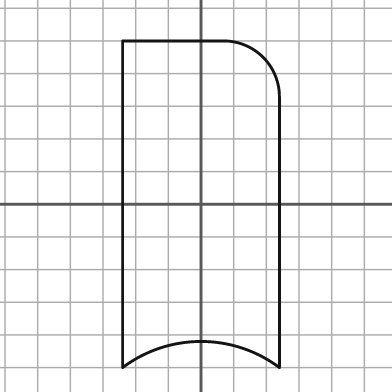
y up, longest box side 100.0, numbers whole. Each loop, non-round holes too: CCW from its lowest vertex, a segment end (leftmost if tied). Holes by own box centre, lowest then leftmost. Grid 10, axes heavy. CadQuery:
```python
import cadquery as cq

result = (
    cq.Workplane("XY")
    .moveTo(-24.0, -50.0)
    .threePointArc((0.0, -42.0), (24.0, -50.0))
    .lineTo(24.0, 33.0)
    .threePointArc((19.0, 45.0), (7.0, 50.0))
    .lineTo(-24.0, 50.0)
    .close()
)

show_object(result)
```